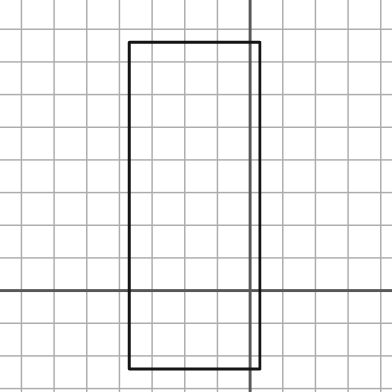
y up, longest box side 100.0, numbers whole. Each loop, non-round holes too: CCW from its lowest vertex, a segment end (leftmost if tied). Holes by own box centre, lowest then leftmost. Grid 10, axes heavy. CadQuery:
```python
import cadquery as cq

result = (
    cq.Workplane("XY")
    .moveTo(-37.0, -24.0)
    .lineTo(3.0, -24.0)
    .lineTo(3.0, 76.0)
    .lineTo(-37.0, 76.0)
    .close()
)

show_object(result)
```